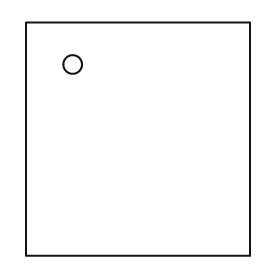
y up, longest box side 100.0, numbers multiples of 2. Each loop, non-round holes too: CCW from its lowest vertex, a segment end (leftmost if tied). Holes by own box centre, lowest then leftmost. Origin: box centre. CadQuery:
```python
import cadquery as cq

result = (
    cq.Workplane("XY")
    .moveTo(-48.0, -50.0)
    .lineTo(48.0, -50.0)
    .lineTo(48.0, 50.0)
    .lineTo(-48.0, 50.0)
    .close()
    .moveTo(-28.0, 32.0)
    .circle(4.0)
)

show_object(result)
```